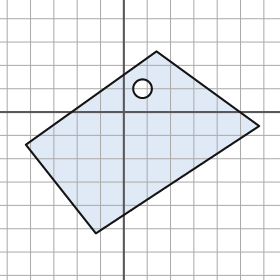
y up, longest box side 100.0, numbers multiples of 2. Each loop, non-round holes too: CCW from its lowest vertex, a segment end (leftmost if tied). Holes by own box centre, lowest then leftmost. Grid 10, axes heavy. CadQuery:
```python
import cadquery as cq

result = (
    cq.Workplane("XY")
    .moveTo(-12.0, -52.0)
    .lineTo(58.0, -6.0)
    .lineTo(14.0, 26.0)
    .lineTo(-42.0, -14.0)
    .close()
    .moveTo(8.0, 10.0)
    .circle(4.0)
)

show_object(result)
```